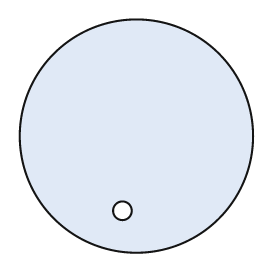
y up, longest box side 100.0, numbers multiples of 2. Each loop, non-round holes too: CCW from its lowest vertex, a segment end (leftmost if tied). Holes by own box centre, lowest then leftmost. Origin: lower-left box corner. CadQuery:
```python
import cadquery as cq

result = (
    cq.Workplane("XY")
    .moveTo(50.0, 50.0)
    .circle(50.0)
    .moveTo(44.0, 18.0)
    .circle(4.0)
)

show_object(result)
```